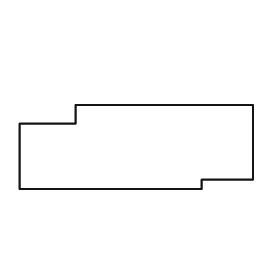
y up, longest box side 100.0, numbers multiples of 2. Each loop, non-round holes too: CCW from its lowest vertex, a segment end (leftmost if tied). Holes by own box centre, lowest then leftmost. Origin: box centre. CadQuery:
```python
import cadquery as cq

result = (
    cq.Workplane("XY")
    .moveTo(-50.0, -18.0)
    .lineTo(28.0, -18.0)
    .lineTo(28.0, -14.0)
    .lineTo(50.0, -14.0)
    .lineTo(50.0, 18.0)
    .lineTo(-26.0, 18.0)
    .lineTo(-26.0, 10.0)
    .lineTo(-50.0, 10.0)
    .close()
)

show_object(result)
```